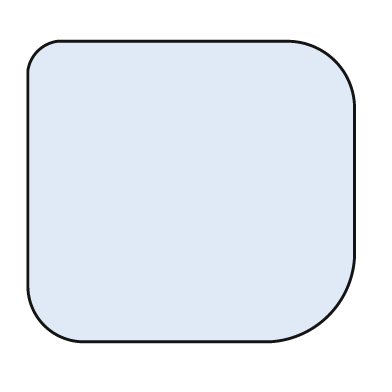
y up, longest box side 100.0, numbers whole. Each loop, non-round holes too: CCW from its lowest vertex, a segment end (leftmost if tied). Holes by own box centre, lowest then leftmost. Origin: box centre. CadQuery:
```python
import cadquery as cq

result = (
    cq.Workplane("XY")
    .moveTo(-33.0, -46.0)
    .lineTo(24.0, -46.0)
    .threePointArc((42.0, -38.0), (50.0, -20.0))
    .lineTo(50.0, 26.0)
    .threePointArc((44.0, 40.0), (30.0, 46.0))
    .lineTo(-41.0, 46.0)
    .threePointArc((-47.0, 43.0), (-50.0, 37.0))
    .lineTo(-50.0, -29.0)
    .threePointArc((-45.0, -41.0), (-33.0, -46.0))
    .close()
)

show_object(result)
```